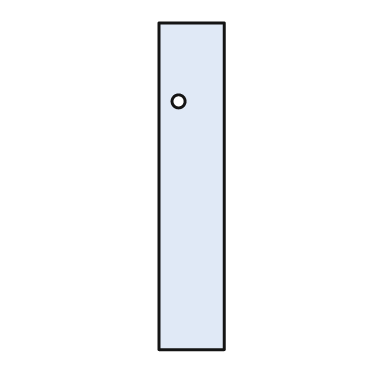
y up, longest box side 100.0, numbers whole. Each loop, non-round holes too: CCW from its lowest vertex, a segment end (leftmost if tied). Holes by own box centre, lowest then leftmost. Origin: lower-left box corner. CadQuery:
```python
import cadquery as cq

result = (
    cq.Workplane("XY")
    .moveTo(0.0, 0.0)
    .lineTo(20.0, 0.0)
    .lineTo(20.0, 100.0)
    .lineTo(0.0, 100.0)
    .close()
    .moveTo(6.0, 76.0)
    .circle(2.0)
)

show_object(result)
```